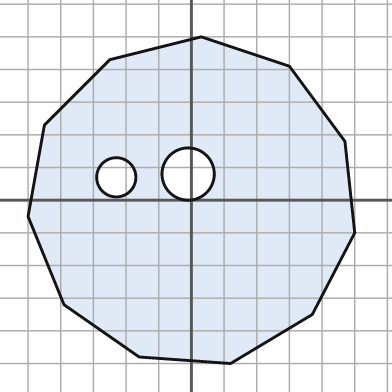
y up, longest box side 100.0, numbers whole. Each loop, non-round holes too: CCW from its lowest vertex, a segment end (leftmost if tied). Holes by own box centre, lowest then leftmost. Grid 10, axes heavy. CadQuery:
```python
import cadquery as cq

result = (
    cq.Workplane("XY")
    .moveTo(12.0, -50.0)
    .lineTo(37.0, -35.0)
    .lineTo(50.0, -10.0)
    .lineTo(47.0, 18.0)
    .lineTo(30.0, 41.0)
    .lineTo(3.0, 50.0)
    .lineTo(-25.0, 43.0)
    .lineTo(-45.0, 23.0)
    .lineTo(-50.0, -5.0)
    .lineTo(-39.0, -32.0)
    .lineTo(-16.0, -48.0)
    .close()
    .moveTo(-23.0, 7.0)
    .circle(6.0)
    .moveTo(-1.0, 8.0)
    .circle(8.0)
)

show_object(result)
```